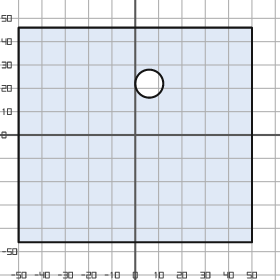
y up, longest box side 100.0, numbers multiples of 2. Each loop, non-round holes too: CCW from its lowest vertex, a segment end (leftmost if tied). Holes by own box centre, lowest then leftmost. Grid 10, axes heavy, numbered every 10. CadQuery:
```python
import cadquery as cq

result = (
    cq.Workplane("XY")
    .moveTo(-50.0, -46.0)
    .lineTo(50.0, -46.0)
    .lineTo(50.0, 46.0)
    .lineTo(-50.0, 46.0)
    .close()
    .moveTo(6.0, 22.0)
    .circle(6.0)
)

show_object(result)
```